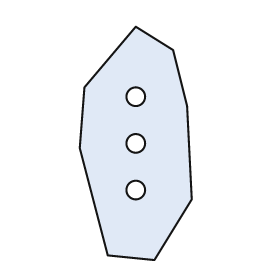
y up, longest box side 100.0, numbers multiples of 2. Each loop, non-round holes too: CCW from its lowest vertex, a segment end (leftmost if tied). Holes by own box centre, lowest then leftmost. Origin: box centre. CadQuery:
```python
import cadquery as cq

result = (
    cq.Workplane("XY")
    .moveTo(8.0, -50.0)
    .lineTo(24.0, -24.0)
    .lineTo(22.0, 16.0)
    .lineTo(16.0, 40.0)
    .lineTo(0.0, 50.0)
    .lineTo(-22.0, 24.0)
    .lineTo(-24.0, -2.0)
    .lineTo(-12.0, -48.0)
    .close()
    .moveTo(0.0, -20.0)
    .circle(4.0)
    .moveTo(0.0, 0.0)
    .circle(4.0)
    .moveTo(0.0, 20.0)
    .circle(4.0)
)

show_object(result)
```